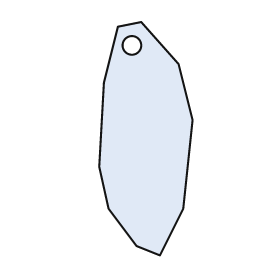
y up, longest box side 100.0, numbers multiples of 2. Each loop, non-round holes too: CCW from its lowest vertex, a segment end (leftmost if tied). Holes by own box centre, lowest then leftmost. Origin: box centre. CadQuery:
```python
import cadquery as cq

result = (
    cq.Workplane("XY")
    .moveTo(6.0, -50.0)
    .lineTo(16.0, -30.0)
    .lineTo(20.0, 8.0)
    .lineTo(14.0, 32.0)
    .lineTo(-2.0, 50.0)
    .lineTo(-12.0, 48.0)
    .lineTo(-18.0, 24.0)
    .lineTo(-20.0, -12.0)
    .lineTo(-16.0, -30.0)
    .lineTo(-4.0, -46.0)
    .close()
    .moveTo(-6.0, 40.0)
    .circle(4.0)
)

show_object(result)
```